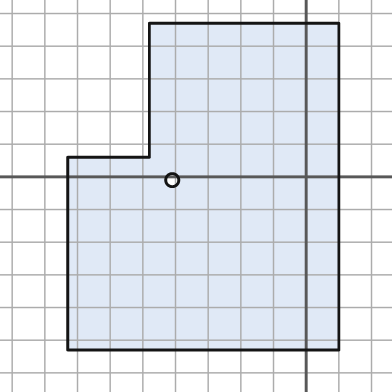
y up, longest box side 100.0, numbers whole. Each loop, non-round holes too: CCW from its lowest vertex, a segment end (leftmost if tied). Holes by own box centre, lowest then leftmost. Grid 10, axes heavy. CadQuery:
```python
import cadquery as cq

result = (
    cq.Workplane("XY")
    .moveTo(-73.0, -53.0)
    .lineTo(10.0, -53.0)
    .lineTo(10.0, 47.0)
    .lineTo(-48.0, 47.0)
    .lineTo(-48.0, 6.0)
    .lineTo(-73.0, 6.0)
    .close()
    .moveTo(-41.0, -1.0)
    .circle(2.0)
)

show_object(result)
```